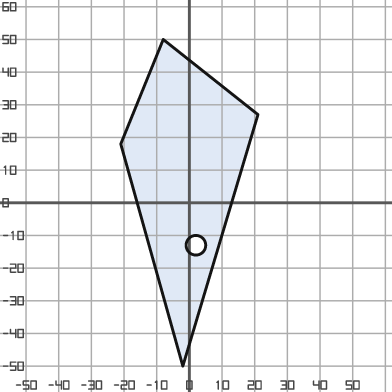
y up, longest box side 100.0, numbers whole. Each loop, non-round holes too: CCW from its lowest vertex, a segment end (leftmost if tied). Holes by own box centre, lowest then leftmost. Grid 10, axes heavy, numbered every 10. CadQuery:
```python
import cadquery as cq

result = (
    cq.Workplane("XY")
    .moveTo(-2.0, -50.0)
    .lineTo(21.0, 27.0)
    .lineTo(-8.0, 50.0)
    .lineTo(-21.0, 18.0)
    .close()
    .moveTo(2.0, -13.0)
    .circle(3.0)
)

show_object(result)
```